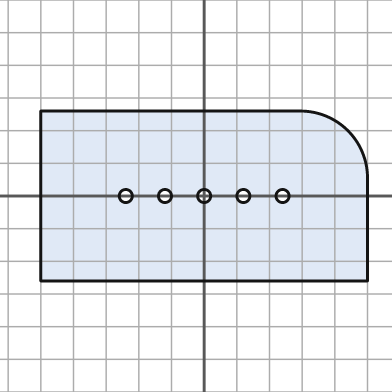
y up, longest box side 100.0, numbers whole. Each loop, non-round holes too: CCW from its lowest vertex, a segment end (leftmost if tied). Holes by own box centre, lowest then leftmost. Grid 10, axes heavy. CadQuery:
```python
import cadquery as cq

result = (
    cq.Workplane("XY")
    .moveTo(-50.0, -26.0)
    .lineTo(50.0, -26.0)
    .lineTo(50.0, 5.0)
    .threePointArc((44.0, 20.0), (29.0, 26.0))
    .lineTo(-50.0, 26.0)
    .close()
    .moveTo(-24.0, 0.0)
    .circle(2.0)
    .moveTo(-12.0, 0.0)
    .circle(2.0)
    .moveTo(0.0, 0.0)
    .circle(2.0)
    .moveTo(12.0, 0.0)
    .circle(2.0)
    .moveTo(24.0, 0.0)
    .circle(2.0)
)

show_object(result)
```